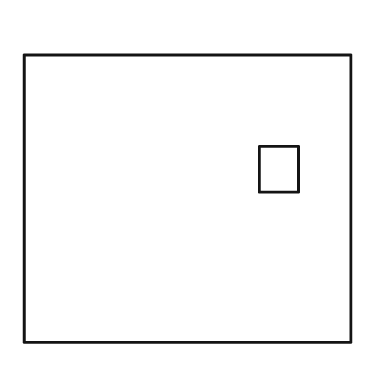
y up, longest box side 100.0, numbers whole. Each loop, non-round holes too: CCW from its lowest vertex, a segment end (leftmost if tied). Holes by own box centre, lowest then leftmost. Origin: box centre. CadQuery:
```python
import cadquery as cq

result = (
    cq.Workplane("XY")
    .moveTo(-50.0, -44.0)
    .lineTo(50.0, -44.0)
    .lineTo(50.0, 44.0)
    .lineTo(-50.0, 44.0)
    .close()
    .moveTo(22.0, 2.0)
    .lineTo(34.0, 2.0)
    .lineTo(34.0, 16.0)
    .lineTo(22.0, 16.0)
    .close()
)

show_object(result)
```